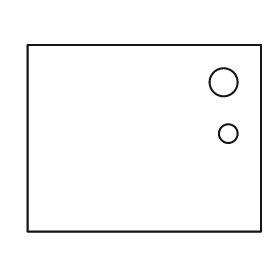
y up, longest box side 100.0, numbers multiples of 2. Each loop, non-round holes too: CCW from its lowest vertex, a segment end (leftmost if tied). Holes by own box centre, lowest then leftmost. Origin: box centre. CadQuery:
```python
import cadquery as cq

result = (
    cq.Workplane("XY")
    .moveTo(-50.0, -40.0)
    .lineTo(50.0, -40.0)
    .lineTo(50.0, 40.0)
    .lineTo(-50.0, 40.0)
    .close()
    .moveTo(36.0, 2.0)
    .circle(4.0)
    .moveTo(34.0, 24.0)
    .circle(6.0)
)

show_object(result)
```